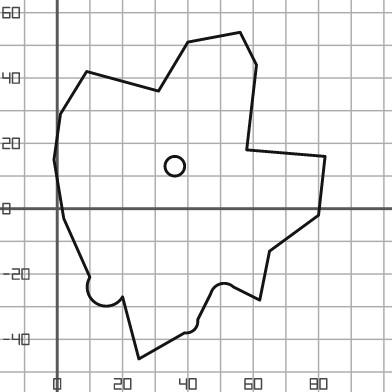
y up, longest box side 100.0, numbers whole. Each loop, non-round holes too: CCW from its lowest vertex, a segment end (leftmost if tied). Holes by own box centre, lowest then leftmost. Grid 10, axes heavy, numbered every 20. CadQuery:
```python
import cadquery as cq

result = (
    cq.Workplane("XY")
    .moveTo(25.0, -46.0)
    .lineTo(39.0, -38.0)
    .threePointArc((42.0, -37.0), (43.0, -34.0))
    .lineTo(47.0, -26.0)
    .threePointArc((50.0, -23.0), (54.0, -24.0))
    .lineTo(62.0, -28.0)
    .lineTo(65.0, -13.0)
    .lineTo(80.0, -2.0)
    .lineTo(82.0, 16.0)
    .lineTo(58.0, 18.0)
    .lineTo(61.0, 44.0)
    .lineTo(56.0, 54.0)
    .lineTo(40.0, 51.0)
    .lineTo(31.0, 36.0)
    .lineTo(9.0, 42.0)
    .lineTo(1.0, 29.0)
    .lineTo(-1.0, 15.0)
    .lineTo(2.0, -3.0)
    .lineTo(10.0, -21.0)
    .threePointArc((12.0, -29.0), (20.0, -27.0))
    .close()
    .moveTo(36.0, 13.0)
    .circle(3.0)
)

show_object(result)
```